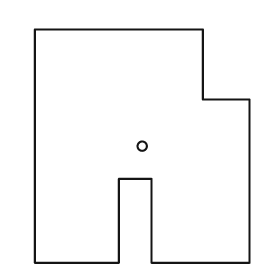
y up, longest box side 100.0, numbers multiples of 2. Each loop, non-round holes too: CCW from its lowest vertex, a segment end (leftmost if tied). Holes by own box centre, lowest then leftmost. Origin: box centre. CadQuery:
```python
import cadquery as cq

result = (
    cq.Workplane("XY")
    .moveTo(-46.0, -50.0)
    .lineTo(-10.0, -50.0)
    .lineTo(-10.0, -14.0)
    .lineTo(4.0, -14.0)
    .lineTo(4.0, -50.0)
    .lineTo(46.0, -50.0)
    .lineTo(46.0, 20.0)
    .lineTo(26.0, 20.0)
    .lineTo(26.0, 50.0)
    .lineTo(-46.0, 50.0)
    .close()
    .moveTo(0.0, 0.0)
    .circle(2.0)
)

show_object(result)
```